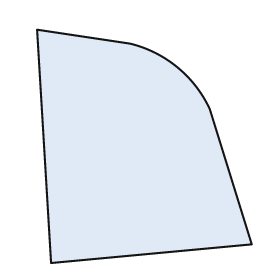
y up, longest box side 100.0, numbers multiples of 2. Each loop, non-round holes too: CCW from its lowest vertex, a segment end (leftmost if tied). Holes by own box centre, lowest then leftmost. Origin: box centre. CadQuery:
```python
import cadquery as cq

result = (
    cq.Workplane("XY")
    .moveTo(-40.0, -50.0)
    .lineTo(46.0, -42.0)
    .lineTo(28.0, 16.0)
    .threePointArc((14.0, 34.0), (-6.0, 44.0))
    .lineTo(-46.0, 50.0)
    .close()
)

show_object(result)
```